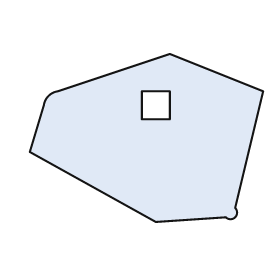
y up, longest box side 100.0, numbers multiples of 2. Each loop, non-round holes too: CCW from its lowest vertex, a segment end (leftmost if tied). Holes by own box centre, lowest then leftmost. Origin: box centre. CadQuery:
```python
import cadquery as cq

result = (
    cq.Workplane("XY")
    .moveTo(4.0, -36.0)
    .lineTo(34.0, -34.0)
    .threePointArc((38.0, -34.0), (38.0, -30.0))
    .lineTo(50.0, 20.0)
    .lineTo(10.0, 36.0)
    .lineTo(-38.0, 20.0)
    .threePointArc((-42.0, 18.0), (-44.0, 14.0))
    .lineTo(-50.0, -6.0)
    .close()
    .moveTo(-2.0, 8.0)
    .lineTo(10.0, 8.0)
    .lineTo(10.0, 20.0)
    .lineTo(-2.0, 20.0)
    .close()
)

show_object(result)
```